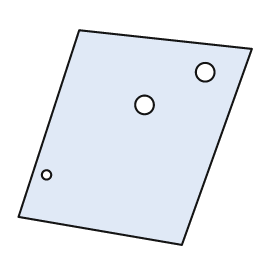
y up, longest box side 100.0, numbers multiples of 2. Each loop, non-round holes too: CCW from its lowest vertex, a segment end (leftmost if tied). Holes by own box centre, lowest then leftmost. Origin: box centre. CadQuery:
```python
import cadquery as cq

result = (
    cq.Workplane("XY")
    .moveTo(20.0, -46.0)
    .lineTo(50.0, 38.0)
    .lineTo(-24.0, 46.0)
    .lineTo(-50.0, -34.0)
    .close()
    .moveTo(-38.0, -16.0)
    .circle(2.0)
    .moveTo(4.0, 14.0)
    .circle(4.0)
    .moveTo(30.0, 28.0)
    .circle(4.0)
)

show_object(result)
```